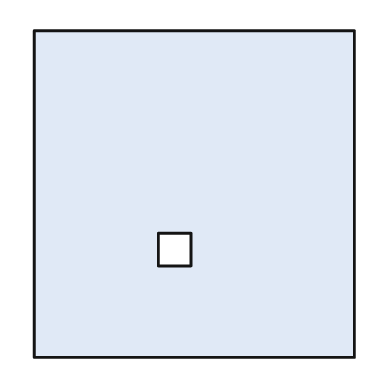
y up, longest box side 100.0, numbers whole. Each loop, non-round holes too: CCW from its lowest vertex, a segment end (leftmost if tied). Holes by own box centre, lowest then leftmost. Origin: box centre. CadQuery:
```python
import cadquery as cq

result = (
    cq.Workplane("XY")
    .moveTo(-49.0, -50.0)
    .lineTo(49.0, -50.0)
    .lineTo(49.0, 50.0)
    .lineTo(-49.0, 50.0)
    .close()
    .moveTo(-11.0, -22.0)
    .lineTo(-1.0, -22.0)
    .lineTo(-1.0, -12.0)
    .lineTo(-11.0, -12.0)
    .close()
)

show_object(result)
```